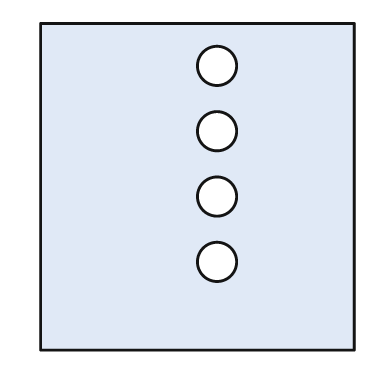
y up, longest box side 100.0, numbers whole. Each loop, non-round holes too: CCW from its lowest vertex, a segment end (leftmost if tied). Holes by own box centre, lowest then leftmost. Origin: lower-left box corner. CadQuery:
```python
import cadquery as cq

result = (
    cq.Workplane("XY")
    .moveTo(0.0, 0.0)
    .lineTo(96.0, 0.0)
    .lineTo(96.0, 100.0)
    .lineTo(0.0, 100.0)
    .close()
    .moveTo(54.0, 27.0)
    .circle(6.0)
    .moveTo(54.0, 47.0)
    .circle(6.0)
    .moveTo(54.0, 67.0)
    .circle(6.0)
    .moveTo(54.0, 87.0)
    .circle(6.0)
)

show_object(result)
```